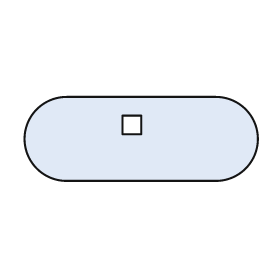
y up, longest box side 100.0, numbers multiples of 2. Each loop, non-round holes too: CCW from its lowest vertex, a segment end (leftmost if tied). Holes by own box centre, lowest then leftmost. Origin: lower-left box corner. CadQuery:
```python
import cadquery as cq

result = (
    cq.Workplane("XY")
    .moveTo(18.0, 0.0)
    .lineTo(82.0, 0.0)
    .threePointArc((100.0, 18.0), (82.0, 36.0))
    .lineTo(18.0, 36.0)
    .threePointArc((0.0, 18.0), (18.0, 0.0))
    .close()
    .moveTo(42.0, 20.0)
    .lineTo(50.0, 20.0)
    .lineTo(50.0, 28.0)
    .lineTo(42.0, 28.0)
    .close()
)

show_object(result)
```